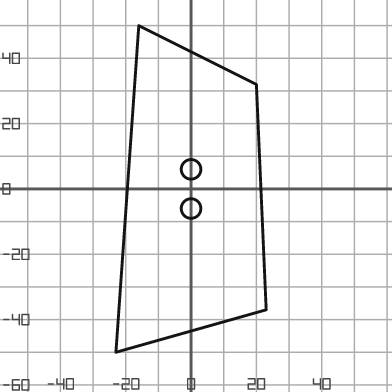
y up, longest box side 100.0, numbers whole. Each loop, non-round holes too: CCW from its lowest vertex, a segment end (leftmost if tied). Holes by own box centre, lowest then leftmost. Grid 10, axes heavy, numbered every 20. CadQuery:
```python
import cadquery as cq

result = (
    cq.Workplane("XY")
    .moveTo(-23.0, -50.0)
    .lineTo(23.0, -37.0)
    .lineTo(20.0, 32.0)
    .lineTo(-16.0, 50.0)
    .close()
    .moveTo(0.0, -6.0)
    .circle(3.0)
    .moveTo(0.0, 6.0)
    .circle(3.0)
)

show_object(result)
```